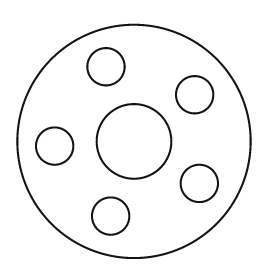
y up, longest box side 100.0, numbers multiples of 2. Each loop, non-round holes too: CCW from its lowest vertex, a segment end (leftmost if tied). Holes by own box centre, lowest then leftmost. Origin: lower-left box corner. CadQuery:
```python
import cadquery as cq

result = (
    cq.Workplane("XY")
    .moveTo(50.0, 50.0)
    .circle(50.0)
    .moveTo(40.0, 18.0)
    .circle(8.0)
    .moveTo(78.0, 32.0)
    .circle(8.0)
    .moveTo(16.0, 48.0)
    .circle(8.0)
    .moveTo(50.0, 50.0)
    .circle(16.0)
    .moveTo(76.0, 70.0)
    .circle(8.0)
    .moveTo(38.0, 82.0)
    .circle(8.0)
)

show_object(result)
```